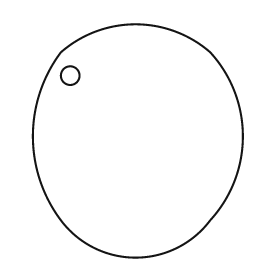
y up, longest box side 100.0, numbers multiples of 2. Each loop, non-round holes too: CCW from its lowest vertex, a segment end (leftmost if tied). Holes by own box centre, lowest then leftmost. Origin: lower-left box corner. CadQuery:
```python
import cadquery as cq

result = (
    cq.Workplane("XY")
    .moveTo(12.0, 16.0)
    .threePointArc((44.0, 0.0), (76.0, 16.0))
    .threePointArc((90.0, 52.0), (76.0, 88.0))
    .threePointArc((44.0, 100.0), (12.0, 88.0))
    .threePointArc((0.0, 52.0), (12.0, 16.0))
    .close()
    .moveTo(16.0, 78.0)
    .circle(4.0)
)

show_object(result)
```